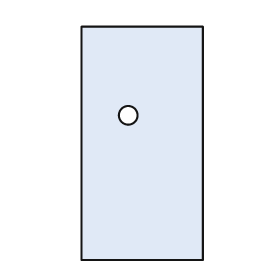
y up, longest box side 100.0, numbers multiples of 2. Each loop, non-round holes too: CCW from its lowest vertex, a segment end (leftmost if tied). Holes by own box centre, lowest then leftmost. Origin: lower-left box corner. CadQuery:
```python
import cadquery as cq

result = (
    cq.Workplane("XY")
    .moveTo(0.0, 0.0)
    .lineTo(52.0, 0.0)
    .lineTo(52.0, 100.0)
    .lineTo(0.0, 100.0)
    .close()
    .moveTo(20.0, 62.0)
    .circle(4.0)
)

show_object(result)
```